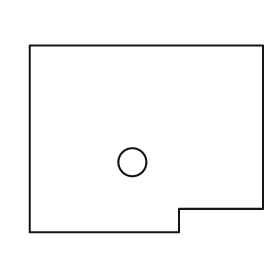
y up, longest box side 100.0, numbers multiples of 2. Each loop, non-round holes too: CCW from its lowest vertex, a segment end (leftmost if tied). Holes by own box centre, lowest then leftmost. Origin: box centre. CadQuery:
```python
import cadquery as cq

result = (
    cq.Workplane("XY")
    .moveTo(-50.0, -40.0)
    .lineTo(14.0, -40.0)
    .lineTo(14.0, -30.0)
    .lineTo(50.0, -30.0)
    .lineTo(50.0, 40.0)
    .lineTo(-50.0, 40.0)
    .close()
    .moveTo(-6.0, -10.0)
    .circle(6.0)
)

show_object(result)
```